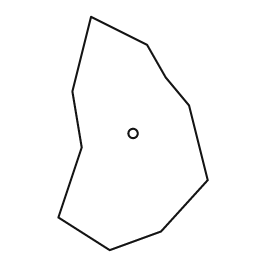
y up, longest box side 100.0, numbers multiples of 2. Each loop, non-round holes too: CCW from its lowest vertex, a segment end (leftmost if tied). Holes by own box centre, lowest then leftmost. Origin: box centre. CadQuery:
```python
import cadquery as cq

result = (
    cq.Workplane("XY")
    .moveTo(-10.0, -50.0)
    .lineTo(12.0, -42.0)
    .lineTo(32.0, -20.0)
    .lineTo(24.0, 12.0)
    .lineTo(14.0, 24.0)
    .lineTo(6.0, 38.0)
    .lineTo(-18.0, 50.0)
    .lineTo(-26.0, 18.0)
    .lineTo(-22.0, -6.0)
    .lineTo(-32.0, -36.0)
    .close()
    .moveTo(0.0, 0.0)
    .circle(2.0)
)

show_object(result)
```